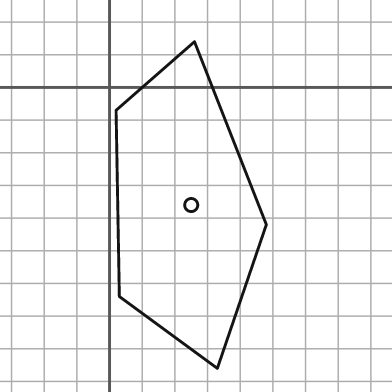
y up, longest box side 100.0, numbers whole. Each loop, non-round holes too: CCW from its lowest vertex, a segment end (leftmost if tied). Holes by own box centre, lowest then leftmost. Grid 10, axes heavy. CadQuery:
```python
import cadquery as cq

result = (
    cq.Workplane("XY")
    .moveTo(33.0, -86.0)
    .lineTo(48.0, -42.0)
    .lineTo(26.0, 14.0)
    .lineTo(2.0, -7.0)
    .lineTo(3.0, -64.0)
    .close()
    .moveTo(25.0, -36.0)
    .circle(2.0)
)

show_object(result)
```